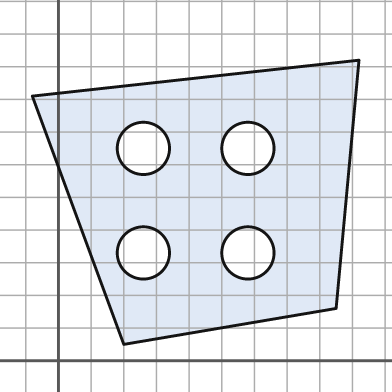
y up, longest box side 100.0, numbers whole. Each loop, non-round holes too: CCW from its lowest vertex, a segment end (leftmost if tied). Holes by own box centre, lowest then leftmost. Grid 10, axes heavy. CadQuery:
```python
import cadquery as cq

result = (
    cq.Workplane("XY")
    .moveTo(20.0, 5.0)
    .lineTo(85.0, 16.0)
    .lineTo(92.0, 92.0)
    .lineTo(-8.0, 81.0)
    .close()
    .moveTo(26.0, 33.0)
    .circle(8.0)
    .moveTo(58.0, 33.0)
    .circle(8.0)
    .moveTo(26.0, 65.0)
    .circle(8.0)
    .moveTo(58.0, 65.0)
    .circle(8.0)
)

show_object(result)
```